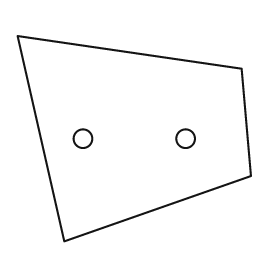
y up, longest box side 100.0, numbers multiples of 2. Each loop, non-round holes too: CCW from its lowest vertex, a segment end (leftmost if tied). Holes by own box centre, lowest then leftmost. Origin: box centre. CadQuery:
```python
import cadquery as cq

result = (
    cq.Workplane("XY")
    .moveTo(-30.0, -44.0)
    .lineTo(50.0, -16.0)
    .lineTo(46.0, 30.0)
    .lineTo(-50.0, 44.0)
    .close()
    .moveTo(-22.0, 0.0)
    .circle(4.0)
    .moveTo(22.0, 0.0)
    .circle(4.0)
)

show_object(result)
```